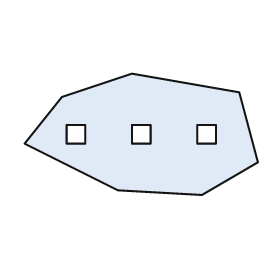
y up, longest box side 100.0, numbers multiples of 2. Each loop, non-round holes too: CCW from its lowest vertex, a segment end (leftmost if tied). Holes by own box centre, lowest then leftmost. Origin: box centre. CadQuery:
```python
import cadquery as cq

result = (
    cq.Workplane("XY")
    .moveTo(26.0, -26.0)
    .lineTo(50.0, -12.0)
    .lineTo(42.0, 18.0)
    .lineTo(-4.0, 26.0)
    .lineTo(-34.0, 16.0)
    .lineTo(-50.0, -4.0)
    .lineTo(-10.0, -24.0)
    .close()
    .moveTo(-32.0, -4.0)
    .lineTo(-24.0, -4.0)
    .lineTo(-24.0, 4.0)
    .lineTo(-32.0, 4.0)
    .close()
    .moveTo(-4.0, -4.0)
    .lineTo(4.0, -4.0)
    .lineTo(4.0, 4.0)
    .lineTo(-4.0, 4.0)
    .close()
    .moveTo(24.0, -4.0)
    .lineTo(32.0, -4.0)
    .lineTo(32.0, 4.0)
    .lineTo(24.0, 4.0)
    .close()
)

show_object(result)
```